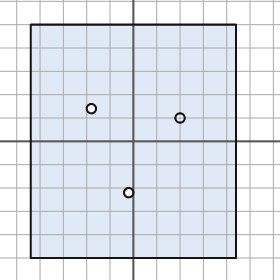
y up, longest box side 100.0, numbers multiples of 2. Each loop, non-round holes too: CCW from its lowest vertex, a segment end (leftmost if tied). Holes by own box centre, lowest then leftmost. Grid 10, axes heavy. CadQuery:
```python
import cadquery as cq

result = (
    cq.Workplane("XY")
    .moveTo(-44.0, -50.0)
    .lineTo(44.0, -50.0)
    .lineTo(44.0, 50.0)
    .lineTo(-44.0, 50.0)
    .close()
    .moveTo(-2.0, -22.0)
    .circle(2.0)
    .moveTo(20.0, 10.0)
    .circle(2.0)
    .moveTo(-18.0, 14.0)
    .circle(2.0)
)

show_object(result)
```